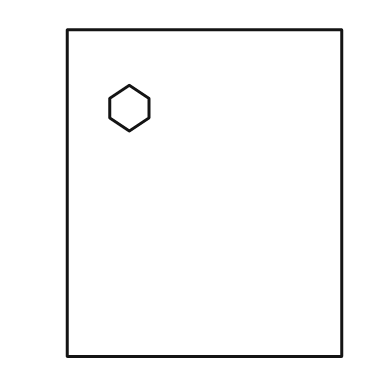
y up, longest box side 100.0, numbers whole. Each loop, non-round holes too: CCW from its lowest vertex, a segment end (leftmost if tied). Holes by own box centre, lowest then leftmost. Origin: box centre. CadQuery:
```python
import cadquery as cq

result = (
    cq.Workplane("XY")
    .moveTo(-42.0, -50.0)
    .lineTo(42.0, -50.0)
    .lineTo(42.0, 50.0)
    .lineTo(-42.0, 50.0)
    .close()
    .moveTo(-23.0, 19.0)
    .lineTo(-17.0, 23.0)
    .lineTo(-17.0, 29.0)
    .lineTo(-23.0, 33.0)
    .lineTo(-29.0, 29.0)
    .lineTo(-29.0, 23.0)
    .close()
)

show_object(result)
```